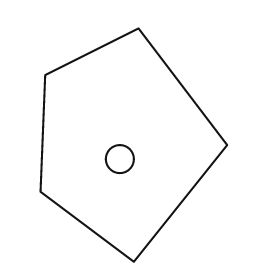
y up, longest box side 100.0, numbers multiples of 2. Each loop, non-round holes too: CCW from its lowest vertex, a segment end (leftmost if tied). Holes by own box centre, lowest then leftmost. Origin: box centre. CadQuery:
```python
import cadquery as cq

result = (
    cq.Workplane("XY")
    .moveTo(0.0, -50.0)
    .lineTo(40.0, 0.0)
    .lineTo(2.0, 50.0)
    .lineTo(-38.0, 30.0)
    .lineTo(-40.0, -20.0)
    .close()
    .moveTo(-6.0, -6.0)
    .circle(6.0)
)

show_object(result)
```